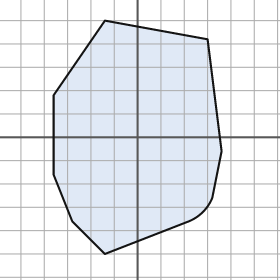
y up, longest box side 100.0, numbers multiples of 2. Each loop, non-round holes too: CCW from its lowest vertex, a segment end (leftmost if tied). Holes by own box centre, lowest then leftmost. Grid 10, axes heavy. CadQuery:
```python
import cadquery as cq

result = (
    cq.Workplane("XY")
    .moveTo(-14.0, -50.0)
    .lineTo(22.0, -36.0)
    .threePointArc((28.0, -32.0), (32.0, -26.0))
    .lineTo(36.0, -6.0)
    .lineTo(30.0, 42.0)
    .lineTo(-14.0, 50.0)
    .lineTo(-36.0, 18.0)
    .lineTo(-36.0, -16.0)
    .lineTo(-28.0, -36.0)
    .close()
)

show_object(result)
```